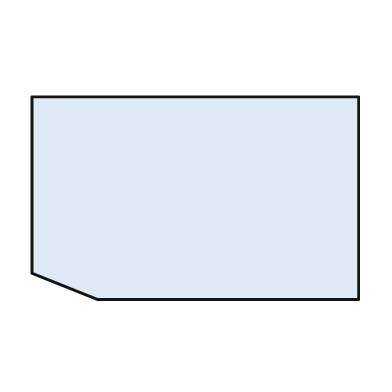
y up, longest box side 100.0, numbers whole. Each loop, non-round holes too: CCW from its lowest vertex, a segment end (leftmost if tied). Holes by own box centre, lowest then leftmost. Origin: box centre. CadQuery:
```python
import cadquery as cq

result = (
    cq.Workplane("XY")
    .moveTo(-30.0, -31.0)
    .lineTo(50.0, -31.0)
    .lineTo(50.0, 31.0)
    .lineTo(-50.0, 31.0)
    .lineTo(-50.0, -23.0)
    .close()
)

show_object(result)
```